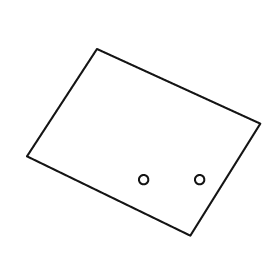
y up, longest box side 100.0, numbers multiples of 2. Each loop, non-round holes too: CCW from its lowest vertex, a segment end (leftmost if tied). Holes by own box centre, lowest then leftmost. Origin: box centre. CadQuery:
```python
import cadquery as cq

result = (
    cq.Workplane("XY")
    .moveTo(20.0, -40.0)
    .lineTo(50.0, 8.0)
    .lineTo(-20.0, 40.0)
    .lineTo(-50.0, -6.0)
    .close()
    .moveTo(0.0, -16.0)
    .circle(2.0)
    .moveTo(24.0, -16.0)
    .circle(2.0)
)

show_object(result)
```